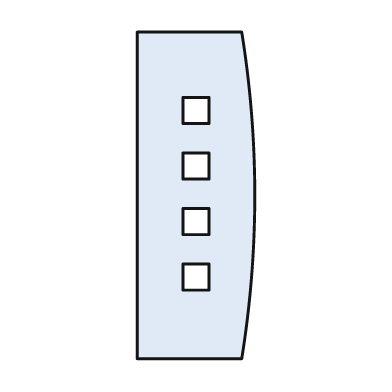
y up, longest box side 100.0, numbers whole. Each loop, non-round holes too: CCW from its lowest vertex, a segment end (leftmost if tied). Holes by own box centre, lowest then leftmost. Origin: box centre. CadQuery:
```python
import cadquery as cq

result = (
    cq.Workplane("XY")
    .moveTo(-18.0, -50.0)
    .lineTo(14.0, -50.0)
    .threePointArc((18.0, 0.0), (14.0, 50.0))
    .lineTo(-18.0, 50.0)
    .close()
    .moveTo(-4.0, -29.0)
    .lineTo(4.0, -29.0)
    .lineTo(4.0, -21.0)
    .lineTo(-4.0, -21.0)
    .close()
    .moveTo(-4.0, -12.0)
    .lineTo(4.0, -12.0)
    .lineTo(4.0, -4.0)
    .lineTo(-4.0, -4.0)
    .close()
    .moveTo(-4.0, 5.0)
    .lineTo(4.0, 5.0)
    .lineTo(4.0, 13.0)
    .lineTo(-4.0, 13.0)
    .close()
    .moveTo(-4.0, 22.0)
    .lineTo(4.0, 22.0)
    .lineTo(4.0, 30.0)
    .lineTo(-4.0, 30.0)
    .close()
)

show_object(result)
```